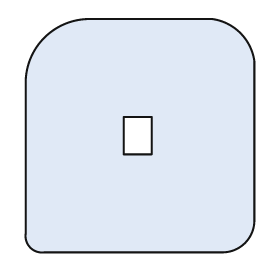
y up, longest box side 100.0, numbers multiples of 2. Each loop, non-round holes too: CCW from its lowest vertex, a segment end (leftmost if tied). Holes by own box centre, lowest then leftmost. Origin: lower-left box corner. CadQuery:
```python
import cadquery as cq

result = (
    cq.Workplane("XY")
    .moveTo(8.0, 0.0)
    .lineTo(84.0, 0.0)
    .threePointArc((94.0, 4.0), (98.0, 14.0))
    .lineTo(98.0, 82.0)
    .threePointArc((92.0, 94.0), (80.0, 100.0))
    .lineTo(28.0, 100.0)
    .threePointArc((8.0, 92.0), (0.0, 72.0))
    .lineTo(0.0, 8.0)
    .threePointArc((2.0, 2.0), (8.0, 0.0))
    .close()
    .moveTo(42.0, 42.0)
    .lineTo(54.0, 42.0)
    .lineTo(54.0, 58.0)
    .lineTo(42.0, 58.0)
    .close()
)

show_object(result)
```